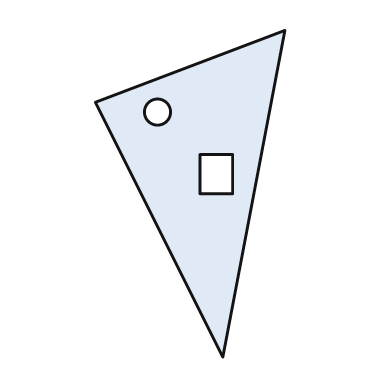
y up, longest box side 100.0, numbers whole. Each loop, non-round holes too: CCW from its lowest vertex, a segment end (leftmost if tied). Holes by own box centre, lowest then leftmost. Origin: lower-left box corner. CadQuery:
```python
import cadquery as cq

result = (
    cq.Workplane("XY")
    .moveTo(39.0, 0.0)
    .lineTo(58.0, 100.0)
    .lineTo(0.0, 78.0)
    .close()
    .moveTo(32.0, 50.0)
    .lineTo(42.0, 50.0)
    .lineTo(42.0, 62.0)
    .lineTo(32.0, 62.0)
    .close()
    .moveTo(19.0, 75.0)
    .circle(4.0)
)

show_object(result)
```